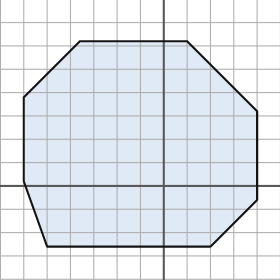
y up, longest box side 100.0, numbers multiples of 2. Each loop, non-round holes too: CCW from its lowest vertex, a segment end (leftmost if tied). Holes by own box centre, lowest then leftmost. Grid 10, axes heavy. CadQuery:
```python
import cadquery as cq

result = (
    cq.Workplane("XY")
    .moveTo(-50.0, -26.0)
    .lineTo(20.0, -26.0)
    .lineTo(40.0, -6.0)
    .lineTo(40.0, 32.0)
    .lineTo(10.0, 62.0)
    .lineTo(-36.0, 62.0)
    .lineTo(-60.0, 38.0)
    .lineTo(-60.0, 2.0)
    .close()
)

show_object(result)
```